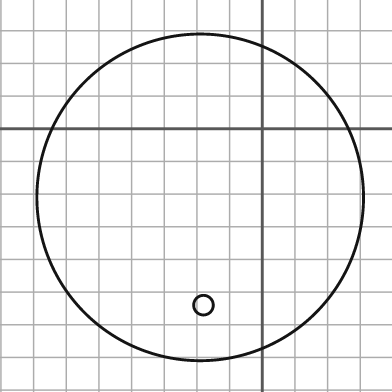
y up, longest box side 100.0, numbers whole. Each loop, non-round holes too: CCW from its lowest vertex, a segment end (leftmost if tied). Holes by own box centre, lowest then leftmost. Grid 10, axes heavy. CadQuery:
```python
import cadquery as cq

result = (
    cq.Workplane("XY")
    .moveTo(-19.0, -21.0)
    .circle(50.0)
    .moveTo(-18.0, -54.0)
    .circle(3.0)
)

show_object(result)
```